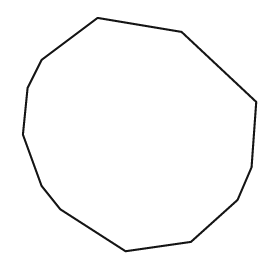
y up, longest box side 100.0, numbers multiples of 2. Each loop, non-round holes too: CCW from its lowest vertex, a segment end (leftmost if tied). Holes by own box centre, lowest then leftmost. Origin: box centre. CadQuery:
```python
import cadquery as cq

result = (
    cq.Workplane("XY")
    .moveTo(-6.0, -50.0)
    .lineTo(22.0, -46.0)
    .lineTo(42.0, -28.0)
    .lineTo(48.0, -14.0)
    .lineTo(50.0, 14.0)
    .lineTo(18.0, 44.0)
    .lineTo(-18.0, 50.0)
    .lineTo(-42.0, 32.0)
    .lineTo(-48.0, 20.0)
    .lineTo(-50.0, 0.0)
    .lineTo(-42.0, -22.0)
    .lineTo(-34.0, -32.0)
    .close()
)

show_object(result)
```